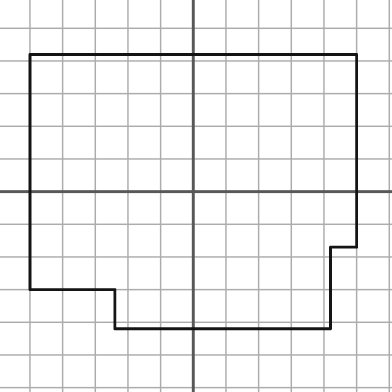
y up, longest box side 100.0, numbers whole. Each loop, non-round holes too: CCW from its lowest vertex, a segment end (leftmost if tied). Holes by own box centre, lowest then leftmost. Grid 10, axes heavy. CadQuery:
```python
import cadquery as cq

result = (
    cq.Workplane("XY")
    .moveTo(-24.0, -42.0)
    .lineTo(42.0, -42.0)
    .lineTo(42.0, -17.0)
    .lineTo(50.0, -17.0)
    .lineTo(50.0, 42.0)
    .lineTo(-50.0, 42.0)
    .lineTo(-50.0, -30.0)
    .lineTo(-24.0, -30.0)
    .close()
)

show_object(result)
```